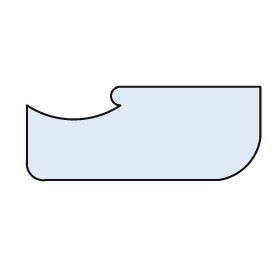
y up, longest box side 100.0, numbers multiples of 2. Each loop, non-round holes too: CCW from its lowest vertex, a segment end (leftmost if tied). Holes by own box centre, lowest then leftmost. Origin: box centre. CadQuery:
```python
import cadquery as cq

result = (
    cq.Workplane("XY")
    .moveTo(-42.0, -20.0)
    .lineTo(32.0, -20.0)
    .threePointArc((44.0, -14.0), (50.0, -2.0))
    .lineTo(50.0, 20.0)
    .lineTo(-10.0, 20.0)
    .threePointArc((-14.0, 16.0), (-10.0, 12.0))
    .threePointArc((-30.0, 6.0), (-50.0, 12.0))
    .lineTo(-50.0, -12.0)
    .threePointArc((-48.0, -18.0), (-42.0, -20.0))
    .close()
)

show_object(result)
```